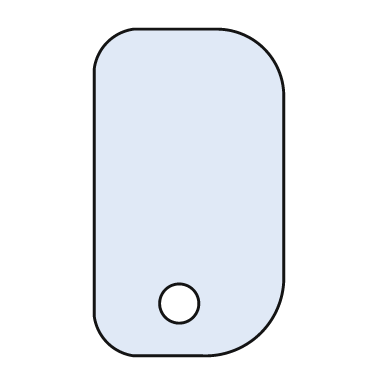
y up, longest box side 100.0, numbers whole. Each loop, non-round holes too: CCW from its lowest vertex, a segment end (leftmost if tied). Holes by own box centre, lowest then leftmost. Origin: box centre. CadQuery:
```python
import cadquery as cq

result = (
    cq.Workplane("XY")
    .moveTo(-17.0, -50.0)
    .lineTo(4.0, -50.0)
    .threePointArc((22.0, -43.0), (29.0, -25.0))
    .lineTo(29.0, 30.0)
    .threePointArc((23.0, 44.0), (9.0, 50.0))
    .lineTo(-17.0, 50.0)
    .threePointArc((-25.0, 46.0), (-29.0, 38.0))
    .lineTo(-29.0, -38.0)
    .threePointArc((-25.0, -46.0), (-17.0, -50.0))
    .close()
    .moveTo(-3.0, -34.0)
    .circle(6.0)
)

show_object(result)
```